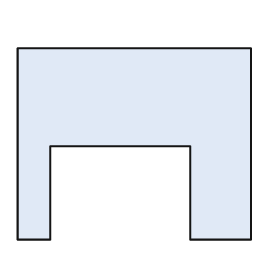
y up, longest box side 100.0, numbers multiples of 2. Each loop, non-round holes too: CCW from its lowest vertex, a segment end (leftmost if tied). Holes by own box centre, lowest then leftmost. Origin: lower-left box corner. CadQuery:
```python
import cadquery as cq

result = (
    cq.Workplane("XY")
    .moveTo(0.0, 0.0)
    .lineTo(14.0, 0.0)
    .lineTo(14.0, 40.0)
    .lineTo(74.0, 40.0)
    .lineTo(74.0, 0.0)
    .lineTo(100.0, 0.0)
    .lineTo(100.0, 82.0)
    .lineTo(0.0, 82.0)
    .close()
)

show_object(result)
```